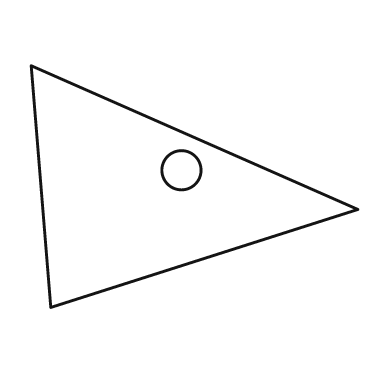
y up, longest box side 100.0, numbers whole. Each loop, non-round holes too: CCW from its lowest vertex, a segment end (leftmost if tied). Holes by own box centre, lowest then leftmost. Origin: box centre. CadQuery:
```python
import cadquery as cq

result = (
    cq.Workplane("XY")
    .moveTo(-44.0, -37.0)
    .lineTo(50.0, -7.0)
    .lineTo(-50.0, 37.0)
    .close()
    .moveTo(-4.0, 5.0)
    .circle(6.0)
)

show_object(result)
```